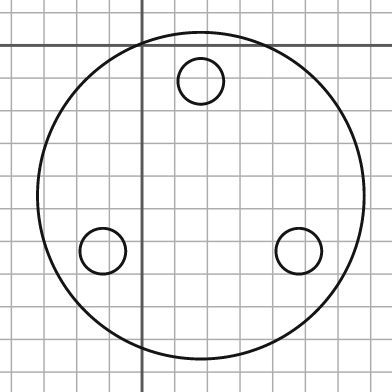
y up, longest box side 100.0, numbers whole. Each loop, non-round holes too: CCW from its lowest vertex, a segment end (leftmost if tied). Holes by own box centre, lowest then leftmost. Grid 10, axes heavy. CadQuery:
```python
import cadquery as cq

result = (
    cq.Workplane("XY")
    .moveTo(18.0, -46.0)
    .circle(50.0)
    .moveTo(-12.0, -63.0)
    .circle(7.0)
    .moveTo(48.0, -63.0)
    .circle(7.0)
    .moveTo(18.0, -11.0)
    .circle(7.0)
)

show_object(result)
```